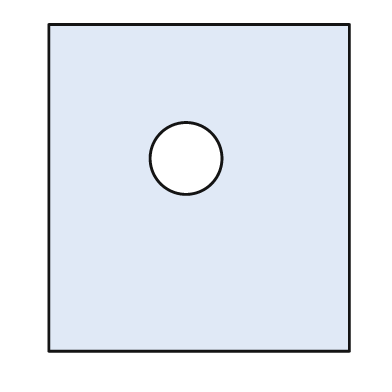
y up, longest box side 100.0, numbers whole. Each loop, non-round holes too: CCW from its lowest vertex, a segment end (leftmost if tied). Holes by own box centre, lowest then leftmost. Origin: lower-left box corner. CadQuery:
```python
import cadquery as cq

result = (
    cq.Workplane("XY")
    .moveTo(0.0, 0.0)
    .lineTo(92.0, 0.0)
    .lineTo(92.0, 100.0)
    .lineTo(0.0, 100.0)
    .close()
    .moveTo(42.0, 59.0)
    .circle(11.0)
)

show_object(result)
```